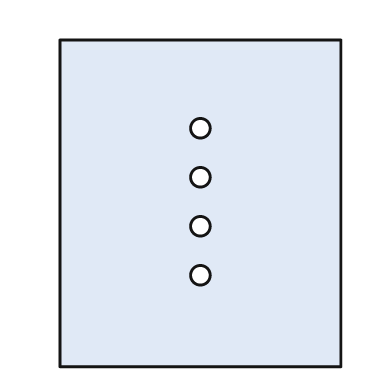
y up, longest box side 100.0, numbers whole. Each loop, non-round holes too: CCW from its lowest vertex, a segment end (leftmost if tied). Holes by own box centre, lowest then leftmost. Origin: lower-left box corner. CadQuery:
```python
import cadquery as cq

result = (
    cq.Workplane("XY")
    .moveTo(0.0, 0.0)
    .lineTo(86.0, 0.0)
    .lineTo(86.0, 100.0)
    .lineTo(0.0, 100.0)
    .close()
    .moveTo(43.0, 28.0)
    .circle(3.0)
    .moveTo(43.0, 43.0)
    .circle(3.0)
    .moveTo(43.0, 58.0)
    .circle(3.0)
    .moveTo(43.0, 73.0)
    .circle(3.0)
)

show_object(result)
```